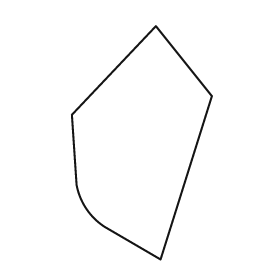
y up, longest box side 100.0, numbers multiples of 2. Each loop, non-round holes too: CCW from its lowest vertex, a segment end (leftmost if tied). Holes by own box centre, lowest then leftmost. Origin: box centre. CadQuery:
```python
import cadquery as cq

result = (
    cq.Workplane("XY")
    .moveTo(8.0, -50.0)
    .lineTo(30.0, 20.0)
    .lineTo(6.0, 50.0)
    .lineTo(-30.0, 12.0)
    .lineTo(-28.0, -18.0)
    .threePointArc((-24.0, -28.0), (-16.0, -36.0))
    .close()
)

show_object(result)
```